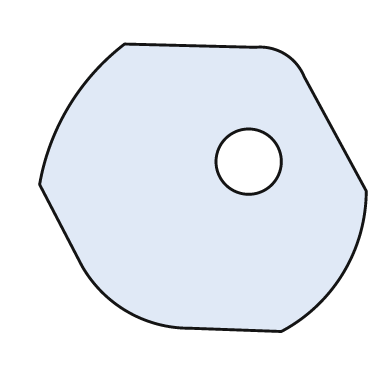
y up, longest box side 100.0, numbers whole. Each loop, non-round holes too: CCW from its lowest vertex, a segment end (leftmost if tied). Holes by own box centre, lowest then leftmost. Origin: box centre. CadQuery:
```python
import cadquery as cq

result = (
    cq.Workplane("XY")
    .moveTo(24.0, -44.0)
    .threePointArc((43.0, -26.0), (50.0, -1.0))
    .lineTo(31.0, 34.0)
    .threePointArc((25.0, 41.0), (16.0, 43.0))
    .lineTo(-24.0, 44.0)
    .threePointArc((-41.0, 25.0), (-50.0, 1.0))
    .lineTo(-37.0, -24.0)
    .threePointArc((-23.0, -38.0), (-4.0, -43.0))
    .close()
    .moveTo(14.0, 8.0)
    .circle(10.0)
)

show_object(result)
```